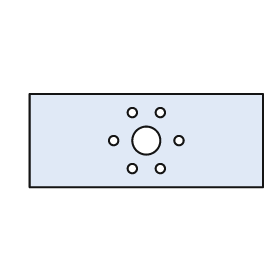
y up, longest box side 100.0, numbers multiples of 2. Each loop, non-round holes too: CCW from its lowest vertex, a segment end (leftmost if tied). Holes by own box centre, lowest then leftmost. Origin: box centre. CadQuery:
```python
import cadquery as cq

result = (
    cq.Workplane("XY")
    .moveTo(-50.0, -20.0)
    .lineTo(50.0, -20.0)
    .lineTo(50.0, 20.0)
    .lineTo(-50.0, 20.0)
    .close()
    .moveTo(-6.0, -12.0)
    .circle(2.0)
    .moveTo(6.0, -12.0)
    .circle(2.0)
    .moveTo(-14.0, 0.0)
    .circle(2.0)
    .moveTo(0.0, 0.0)
    .circle(6.0)
    .moveTo(14.0, 0.0)
    .circle(2.0)
    .moveTo(-6.0, 12.0)
    .circle(2.0)
    .moveTo(6.0, 12.0)
    .circle(2.0)
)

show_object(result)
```